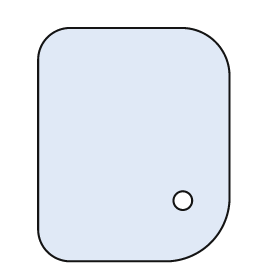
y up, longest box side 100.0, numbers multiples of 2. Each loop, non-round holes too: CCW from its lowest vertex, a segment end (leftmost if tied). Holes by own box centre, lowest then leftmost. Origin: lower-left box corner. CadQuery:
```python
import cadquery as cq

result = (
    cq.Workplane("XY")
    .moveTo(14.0, 0.0)
    .lineTo(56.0, 0.0)
    .threePointArc((74.0, 8.0), (82.0, 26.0))
    .lineTo(82.0, 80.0)
    .threePointArc((76.0, 94.0), (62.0, 100.0))
    .lineTo(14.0, 100.0)
    .threePointArc((4.0, 96.0), (0.0, 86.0))
    .lineTo(0.0, 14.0)
    .threePointArc((4.0, 4.0), (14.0, 0.0))
    .close()
    .moveTo(62.0, 26.0)
    .circle(4.0)
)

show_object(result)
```